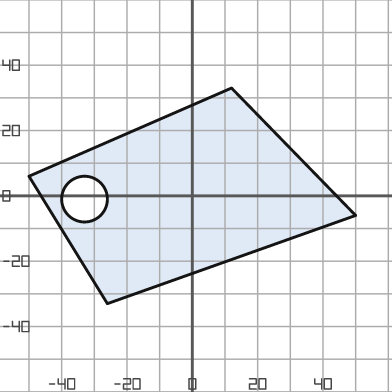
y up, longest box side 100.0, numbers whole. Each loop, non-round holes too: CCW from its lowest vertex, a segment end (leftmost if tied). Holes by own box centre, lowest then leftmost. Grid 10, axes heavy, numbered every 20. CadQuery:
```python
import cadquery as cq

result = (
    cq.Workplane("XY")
    .moveTo(-26.0, -33.0)
    .lineTo(50.0, -6.0)
    .lineTo(12.0, 33.0)
    .lineTo(-50.0, 6.0)
    .close()
    .moveTo(-33.0, -1.0)
    .circle(7.0)
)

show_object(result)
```